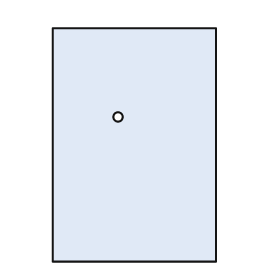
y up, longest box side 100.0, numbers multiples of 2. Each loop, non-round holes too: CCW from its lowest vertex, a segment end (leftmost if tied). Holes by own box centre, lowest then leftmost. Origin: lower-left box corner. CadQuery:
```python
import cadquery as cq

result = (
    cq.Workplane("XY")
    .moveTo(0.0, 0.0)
    .lineTo(70.0, 0.0)
    .lineTo(70.0, 100.0)
    .lineTo(0.0, 100.0)
    .close()
    .moveTo(28.0, 62.0)
    .circle(2.0)
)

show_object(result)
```